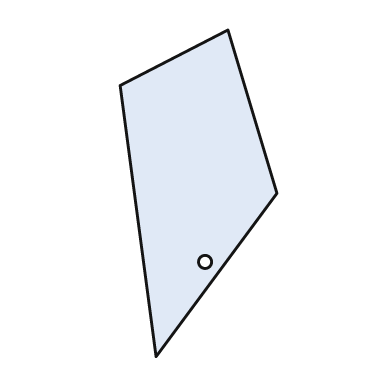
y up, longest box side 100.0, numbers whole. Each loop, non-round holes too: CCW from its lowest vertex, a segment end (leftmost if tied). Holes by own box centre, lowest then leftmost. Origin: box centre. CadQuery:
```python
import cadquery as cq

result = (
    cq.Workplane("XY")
    .moveTo(-13.0, -50.0)
    .lineTo(24.0, 0.0)
    .lineTo(9.0, 50.0)
    .lineTo(-24.0, 33.0)
    .close()
    .moveTo(2.0, -21.0)
    .circle(2.0)
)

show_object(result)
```